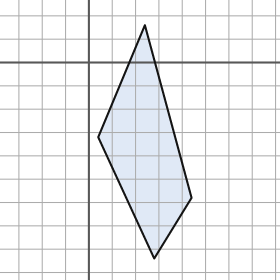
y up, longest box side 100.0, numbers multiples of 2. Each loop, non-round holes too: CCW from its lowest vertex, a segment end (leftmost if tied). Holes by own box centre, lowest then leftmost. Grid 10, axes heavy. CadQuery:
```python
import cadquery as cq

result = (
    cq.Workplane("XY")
    .moveTo(28.0, -84.0)
    .lineTo(44.0, -58.0)
    .lineTo(24.0, 16.0)
    .lineTo(4.0, -32.0)
    .close()
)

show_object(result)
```